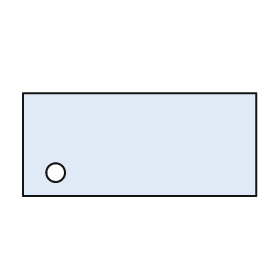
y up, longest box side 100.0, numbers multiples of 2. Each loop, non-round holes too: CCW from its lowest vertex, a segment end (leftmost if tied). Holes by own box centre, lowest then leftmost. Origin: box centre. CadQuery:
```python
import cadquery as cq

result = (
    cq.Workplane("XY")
    .moveTo(-50.0, -22.0)
    .lineTo(50.0, -22.0)
    .lineTo(50.0, 22.0)
    .lineTo(-50.0, 22.0)
    .close()
    .moveTo(-36.0, -12.0)
    .circle(4.0)
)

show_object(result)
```